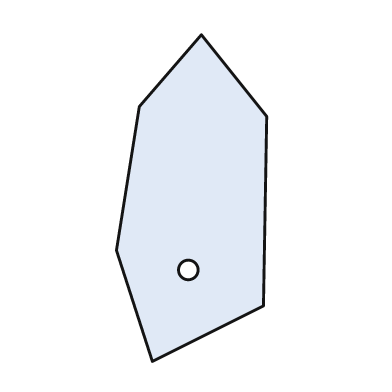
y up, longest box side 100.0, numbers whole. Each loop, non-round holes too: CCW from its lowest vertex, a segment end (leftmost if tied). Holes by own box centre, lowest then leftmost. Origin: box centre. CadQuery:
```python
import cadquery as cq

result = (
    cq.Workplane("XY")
    .moveTo(-12.0, -50.0)
    .lineTo(22.0, -33.0)
    .lineTo(23.0, 25.0)
    .lineTo(3.0, 50.0)
    .lineTo(-16.0, 28.0)
    .lineTo(-23.0, -16.0)
    .close()
    .moveTo(-1.0, -22.0)
    .circle(3.0)
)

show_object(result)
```